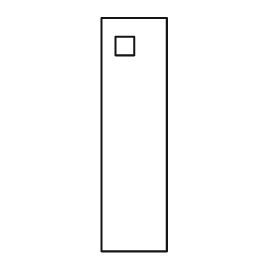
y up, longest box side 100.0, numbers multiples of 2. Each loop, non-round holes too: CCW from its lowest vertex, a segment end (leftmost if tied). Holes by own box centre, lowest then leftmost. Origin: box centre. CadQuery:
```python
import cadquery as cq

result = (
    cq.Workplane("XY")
    .moveTo(-14.0, -50.0)
    .lineTo(14.0, -50.0)
    .lineTo(14.0, 50.0)
    .lineTo(-14.0, 50.0)
    .close()
    .moveTo(-8.0, 34.0)
    .lineTo(0.0, 34.0)
    .lineTo(0.0, 42.0)
    .lineTo(-8.0, 42.0)
    .close()
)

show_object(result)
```